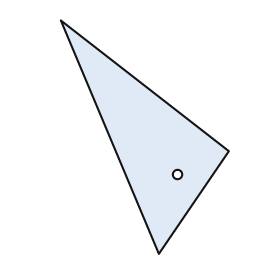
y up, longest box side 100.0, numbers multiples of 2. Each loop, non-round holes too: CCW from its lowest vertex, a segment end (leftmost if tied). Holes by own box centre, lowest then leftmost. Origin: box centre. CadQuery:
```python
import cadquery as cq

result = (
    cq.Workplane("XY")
    .moveTo(6.0, -50.0)
    .lineTo(36.0, -6.0)
    .lineTo(-36.0, 50.0)
    .close()
    .moveTo(14.0, -16.0)
    .circle(2.0)
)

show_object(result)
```